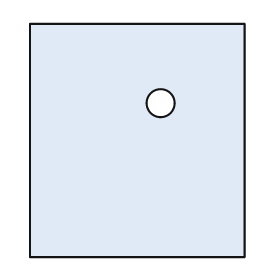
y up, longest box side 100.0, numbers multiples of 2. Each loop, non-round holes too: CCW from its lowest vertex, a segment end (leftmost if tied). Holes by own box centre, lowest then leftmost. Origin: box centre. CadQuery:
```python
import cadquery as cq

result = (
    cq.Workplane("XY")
    .moveTo(-46.0, -50.0)
    .lineTo(46.0, -50.0)
    .lineTo(46.0, 50.0)
    .lineTo(-46.0, 50.0)
    .close()
    .moveTo(10.0, 16.0)
    .circle(6.0)
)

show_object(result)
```